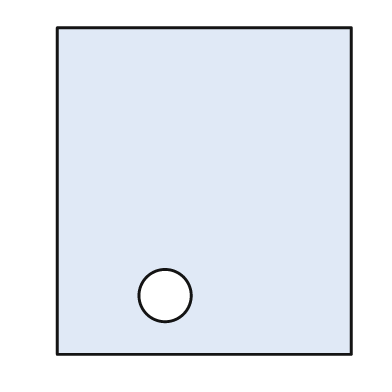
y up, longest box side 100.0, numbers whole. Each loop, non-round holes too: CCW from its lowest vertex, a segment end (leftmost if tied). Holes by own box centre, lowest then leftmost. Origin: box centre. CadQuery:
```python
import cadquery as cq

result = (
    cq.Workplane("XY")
    .moveTo(-45.0, -50.0)
    .lineTo(45.0, -50.0)
    .lineTo(45.0, 50.0)
    .lineTo(-45.0, 50.0)
    .close()
    .moveTo(-12.0, -32.0)
    .circle(8.0)
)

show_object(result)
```